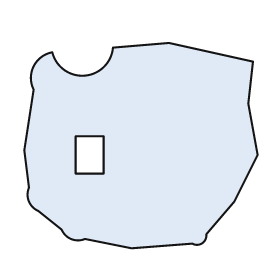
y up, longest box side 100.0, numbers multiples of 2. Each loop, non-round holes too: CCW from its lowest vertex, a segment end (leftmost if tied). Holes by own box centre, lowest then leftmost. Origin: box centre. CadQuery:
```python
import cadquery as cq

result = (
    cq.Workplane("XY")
    .moveTo(-4.0, -44.0)
    .lineTo(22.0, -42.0)
    .threePointArc((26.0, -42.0), (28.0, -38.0))
    .lineTo(40.0, -24.0)
    .lineTo(50.0, -4.0)
    .lineTo(46.0, 18.0)
    .lineTo(48.0, 36.0)
    .lineTo(12.0, 44.0)
    .lineTo(-12.0, 42.0)
    .threePointArc((-24.0, 30.0), (-38.0, 40.0))
    .threePointArc((-46.0, 34.0), (-46.0, 24.0))
    .lineTo(-50.0, -2.0)
    .lineTo(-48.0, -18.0)
    .threePointArc((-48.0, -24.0), (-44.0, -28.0))
    .lineTo(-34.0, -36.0)
    .threePointArc((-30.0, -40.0), (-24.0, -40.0))
    .close()
    .moveTo(-28.0, -12.0)
    .lineTo(-16.0, -12.0)
    .lineTo(-16.0, 4.0)
    .lineTo(-28.0, 4.0)
    .close()
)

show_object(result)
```